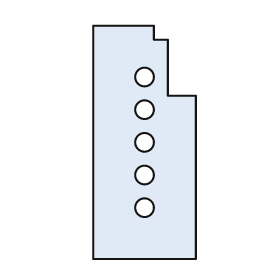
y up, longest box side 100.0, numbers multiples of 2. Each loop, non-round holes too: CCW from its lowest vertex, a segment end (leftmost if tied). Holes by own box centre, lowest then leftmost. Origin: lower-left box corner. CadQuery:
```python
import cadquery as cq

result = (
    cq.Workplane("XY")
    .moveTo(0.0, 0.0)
    .lineTo(44.0, 0.0)
    .lineTo(44.0, 70.0)
    .lineTo(32.0, 70.0)
    .lineTo(32.0, 94.0)
    .lineTo(26.0, 94.0)
    .lineTo(26.0, 100.0)
    .lineTo(0.0, 100.0)
    .close()
    .moveTo(22.0, 22.0)
    .circle(4.0)
    .moveTo(22.0, 36.0)
    .circle(4.0)
    .moveTo(22.0, 50.0)
    .circle(4.0)
    .moveTo(22.0, 64.0)
    .circle(4.0)
    .moveTo(22.0, 78.0)
    .circle(4.0)
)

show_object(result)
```